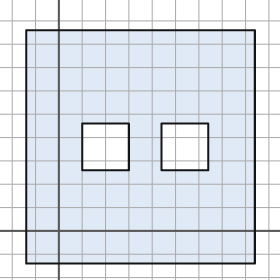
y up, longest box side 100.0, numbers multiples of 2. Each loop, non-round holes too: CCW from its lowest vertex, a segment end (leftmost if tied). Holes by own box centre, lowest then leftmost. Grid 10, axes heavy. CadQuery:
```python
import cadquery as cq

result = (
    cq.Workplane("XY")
    .moveTo(-14.0, -14.0)
    .lineTo(84.0, -14.0)
    .lineTo(84.0, 86.0)
    .lineTo(-14.0, 86.0)
    .close()
    .moveTo(10.0, 26.0)
    .lineTo(30.0, 26.0)
    .lineTo(30.0, 46.0)
    .lineTo(10.0, 46.0)
    .close()
    .moveTo(44.0, 26.0)
    .lineTo(64.0, 26.0)
    .lineTo(64.0, 46.0)
    .lineTo(44.0, 46.0)
    .close()
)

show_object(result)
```